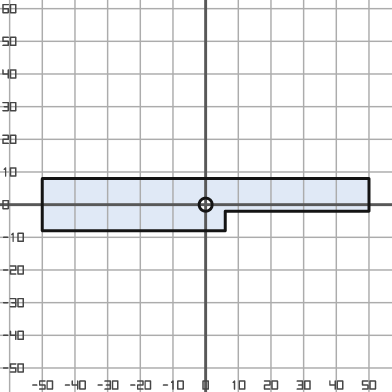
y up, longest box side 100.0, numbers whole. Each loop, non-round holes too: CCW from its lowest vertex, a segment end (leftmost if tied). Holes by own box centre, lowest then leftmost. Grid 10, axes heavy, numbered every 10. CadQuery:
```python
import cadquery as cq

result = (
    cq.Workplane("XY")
    .moveTo(-50.0, -8.0)
    .lineTo(6.0, -8.0)
    .lineTo(6.0, -2.0)
    .lineTo(50.0, -2.0)
    .lineTo(50.0, 8.0)
    .lineTo(-50.0, 8.0)
    .close()
    .moveTo(0.0, 0.0)
    .circle(2.0)
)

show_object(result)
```